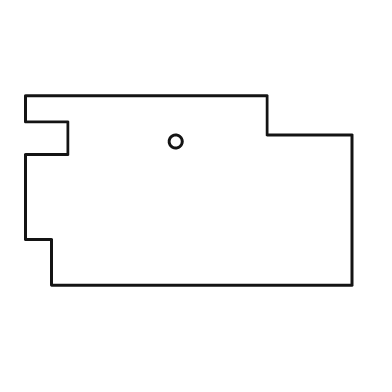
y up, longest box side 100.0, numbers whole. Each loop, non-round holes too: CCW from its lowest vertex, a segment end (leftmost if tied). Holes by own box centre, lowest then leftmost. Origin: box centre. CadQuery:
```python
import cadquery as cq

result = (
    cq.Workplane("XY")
    .moveTo(-42.0, -29.0)
    .lineTo(50.0, -29.0)
    .lineTo(50.0, 17.0)
    .lineTo(24.0, 17.0)
    .lineTo(24.0, 29.0)
    .lineTo(-50.0, 29.0)
    .lineTo(-50.0, 21.0)
    .lineTo(-37.0, 21.0)
    .lineTo(-37.0, 11.0)
    .lineTo(-50.0, 11.0)
    .lineTo(-50.0, -15.0)
    .lineTo(-42.0, -15.0)
    .close()
    .moveTo(-4.0, 15.0)
    .circle(2.0)
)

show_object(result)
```